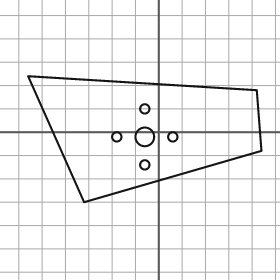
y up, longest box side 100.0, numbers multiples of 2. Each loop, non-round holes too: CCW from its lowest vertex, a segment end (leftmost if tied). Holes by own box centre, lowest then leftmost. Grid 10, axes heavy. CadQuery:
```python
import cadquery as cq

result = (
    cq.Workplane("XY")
    .moveTo(-32.0, -30.0)
    .lineTo(44.0, -8.0)
    .lineTo(42.0, 18.0)
    .lineTo(-56.0, 24.0)
    .close()
    .moveTo(-6.0, -14.0)
    .circle(2.0)
    .moveTo(-18.0, -2.0)
    .circle(2.0)
    .moveTo(-6.0, -2.0)
    .circle(4.0)
    .moveTo(6.0, -2.0)
    .circle(2.0)
    .moveTo(-6.0, 10.0)
    .circle(2.0)
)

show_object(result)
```